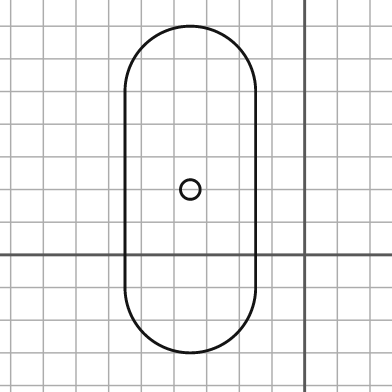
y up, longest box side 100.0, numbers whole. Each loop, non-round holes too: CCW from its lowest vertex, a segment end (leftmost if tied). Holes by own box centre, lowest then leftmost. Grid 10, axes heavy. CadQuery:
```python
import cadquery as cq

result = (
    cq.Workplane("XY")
    .moveTo(-55.0, -10.0)
    .threePointArc((-35.0, -30.0), (-15.0, -10.0))
    .lineTo(-15.0, 50.0)
    .threePointArc((-35.0, 70.0), (-55.0, 50.0))
    .close()
    .moveTo(-35.0, 20.0)
    .circle(3.0)
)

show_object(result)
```